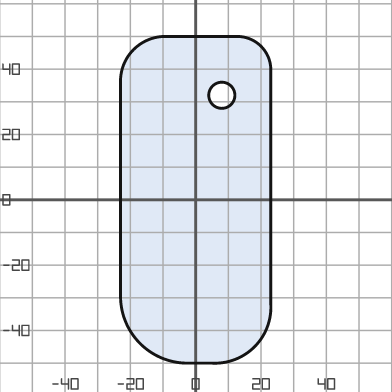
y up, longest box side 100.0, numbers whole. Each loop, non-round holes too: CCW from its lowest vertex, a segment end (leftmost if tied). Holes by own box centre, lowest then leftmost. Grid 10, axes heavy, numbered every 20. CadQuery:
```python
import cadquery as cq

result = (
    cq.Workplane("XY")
    .moveTo(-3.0, -50.0)
    .lineTo(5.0, -50.0)
    .threePointArc((18.0, -45.0), (23.0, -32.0))
    .lineTo(23.0, 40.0)
    .threePointArc((20.0, 47.0), (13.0, 50.0))
    .lineTo(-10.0, 50.0)
    .threePointArc((-19.0, 46.0), (-23.0, 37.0))
    .lineTo(-23.0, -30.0)
    .threePointArc((-17.0, -44.0), (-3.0, -50.0))
    .close()
    .moveTo(8.0, 32.0)
    .circle(4.0)
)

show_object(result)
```